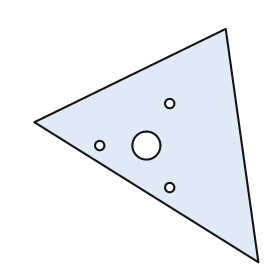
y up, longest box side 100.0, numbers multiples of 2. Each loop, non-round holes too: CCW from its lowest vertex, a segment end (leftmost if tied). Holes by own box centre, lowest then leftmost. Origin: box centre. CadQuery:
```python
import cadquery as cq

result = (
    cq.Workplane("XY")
    .moveTo(48.0, -50.0)
    .lineTo(34.0, 50.0)
    .lineTo(-48.0, 10.0)
    .close()
    .moveTo(10.0, -18.0)
    .circle(2.0)
    .moveTo(-20.0, 0.0)
    .circle(2.0)
    .moveTo(0.0, 0.0)
    .circle(6.0)
    .moveTo(10.0, 18.0)
    .circle(2.0)
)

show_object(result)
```